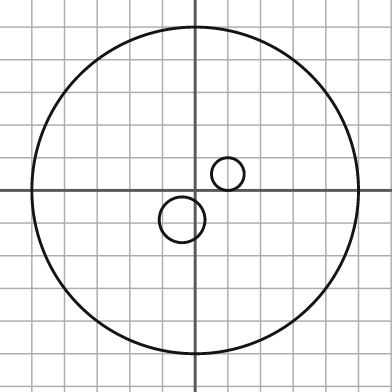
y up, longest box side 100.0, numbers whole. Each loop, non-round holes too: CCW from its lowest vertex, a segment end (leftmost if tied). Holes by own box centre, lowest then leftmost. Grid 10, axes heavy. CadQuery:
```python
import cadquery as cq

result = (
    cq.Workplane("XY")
    .moveTo(0.0, 0.0)
    .circle(50.0)
    .moveTo(-4.0, -9.0)
    .circle(7.0)
    .moveTo(10.0, 5.0)
    .circle(5.0)
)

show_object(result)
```